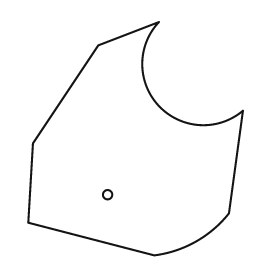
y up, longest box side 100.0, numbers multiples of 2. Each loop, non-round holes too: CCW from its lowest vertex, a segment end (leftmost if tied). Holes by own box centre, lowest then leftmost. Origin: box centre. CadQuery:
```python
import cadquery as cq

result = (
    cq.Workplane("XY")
    .moveTo(8.0, -50.0)
    .threePointArc((26.0, -44.0), (40.0, -32.0))
    .lineTo(46.0, 12.0)
    .threePointArc((10.0, 14.0), (10.0, 50.0))
    .lineTo(-16.0, 40.0)
    .lineTo(-44.0, -2.0)
    .lineTo(-46.0, -36.0)
    .close()
    .moveTo(-12.0, -24.0)
    .circle(2.0)
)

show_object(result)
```